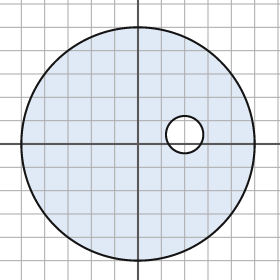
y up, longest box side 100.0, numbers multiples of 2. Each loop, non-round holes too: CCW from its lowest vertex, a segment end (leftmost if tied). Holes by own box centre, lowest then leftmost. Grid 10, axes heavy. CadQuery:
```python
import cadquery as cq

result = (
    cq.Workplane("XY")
    .moveTo(0.0, 0.0)
    .circle(50.0)
    .moveTo(20.0, 4.0)
    .circle(8.0)
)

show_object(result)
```